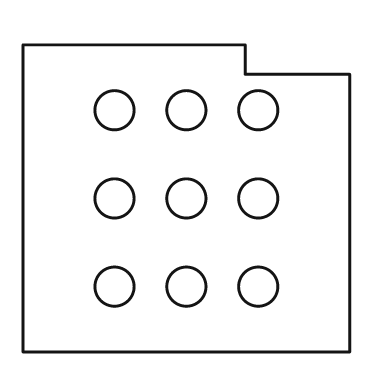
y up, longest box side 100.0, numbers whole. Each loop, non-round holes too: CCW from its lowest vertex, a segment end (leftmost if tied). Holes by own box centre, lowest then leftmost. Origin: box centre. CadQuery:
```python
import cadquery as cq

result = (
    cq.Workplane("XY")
    .moveTo(-50.0, -47.0)
    .lineTo(50.0, -47.0)
    .lineTo(50.0, 38.0)
    .lineTo(18.0, 38.0)
    .lineTo(18.0, 47.0)
    .lineTo(-50.0, 47.0)
    .close()
    .moveTo(-22.0, -27.0)
    .circle(6.0)
    .moveTo(0.0, -27.0)
    .circle(6.0)
    .moveTo(22.0, -27.0)
    .circle(6.0)
    .moveTo(-22.0, 0.0)
    .circle(6.0)
    .moveTo(0.0, 0.0)
    .circle(6.0)
    .moveTo(22.0, 0.0)
    .circle(6.0)
    .moveTo(-22.0, 27.0)
    .circle(6.0)
    .moveTo(0.0, 27.0)
    .circle(6.0)
    .moveTo(22.0, 27.0)
    .circle(6.0)
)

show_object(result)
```